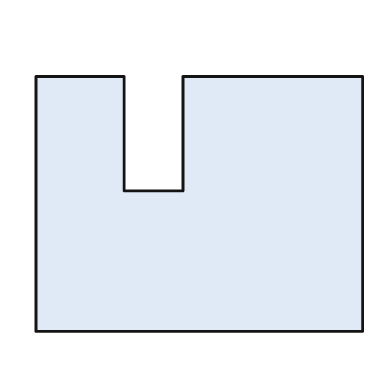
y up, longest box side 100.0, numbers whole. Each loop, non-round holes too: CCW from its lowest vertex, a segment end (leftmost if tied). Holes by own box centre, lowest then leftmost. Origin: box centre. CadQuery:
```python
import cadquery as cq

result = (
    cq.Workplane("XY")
    .moveTo(-50.0, -39.0)
    .lineTo(50.0, -39.0)
    .lineTo(50.0, 39.0)
    .lineTo(-5.0, 39.0)
    .lineTo(-5.0, 4.0)
    .lineTo(-23.0, 4.0)
    .lineTo(-23.0, 39.0)
    .lineTo(-50.0, 39.0)
    .close()
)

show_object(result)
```